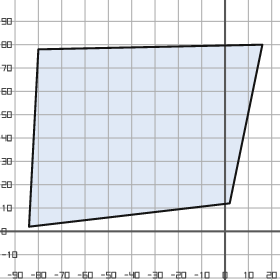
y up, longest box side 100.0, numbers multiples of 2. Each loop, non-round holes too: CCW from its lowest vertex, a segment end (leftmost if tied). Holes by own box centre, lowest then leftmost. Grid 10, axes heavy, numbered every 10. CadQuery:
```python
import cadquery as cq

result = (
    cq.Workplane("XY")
    .moveTo(-84.0, 2.0)
    .lineTo(2.0, 12.0)
    .lineTo(16.0, 80.0)
    .lineTo(-80.0, 78.0)
    .close()
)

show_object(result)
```